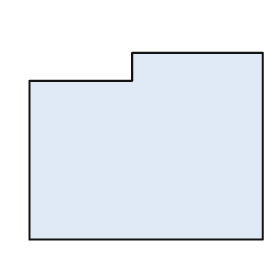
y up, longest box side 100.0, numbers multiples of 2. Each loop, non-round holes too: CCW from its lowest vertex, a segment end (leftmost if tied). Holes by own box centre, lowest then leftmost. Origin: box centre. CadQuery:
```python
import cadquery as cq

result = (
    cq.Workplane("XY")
    .moveTo(-50.0, -40.0)
    .lineTo(50.0, -40.0)
    .lineTo(50.0, 40.0)
    .lineTo(-6.0, 40.0)
    .lineTo(-6.0, 28.0)
    .lineTo(-50.0, 28.0)
    .close()
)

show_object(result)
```